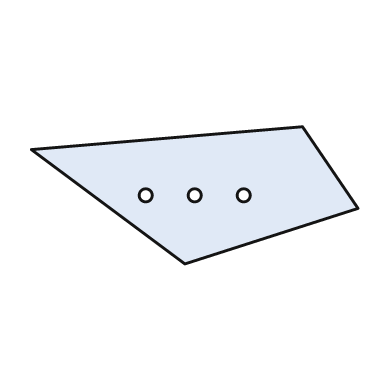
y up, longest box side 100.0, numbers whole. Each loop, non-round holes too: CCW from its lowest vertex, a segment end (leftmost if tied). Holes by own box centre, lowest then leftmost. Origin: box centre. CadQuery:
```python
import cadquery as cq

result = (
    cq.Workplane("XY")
    .moveTo(-3.0, -21.0)
    .lineTo(50.0, -4.0)
    .lineTo(33.0, 21.0)
    .lineTo(-50.0, 14.0)
    .close()
    .moveTo(-15.0, 0.0)
    .circle(2.0)
    .moveTo(0.0, 0.0)
    .circle(2.0)
    .moveTo(15.0, 0.0)
    .circle(2.0)
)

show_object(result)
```